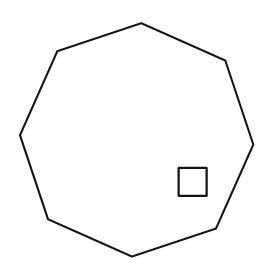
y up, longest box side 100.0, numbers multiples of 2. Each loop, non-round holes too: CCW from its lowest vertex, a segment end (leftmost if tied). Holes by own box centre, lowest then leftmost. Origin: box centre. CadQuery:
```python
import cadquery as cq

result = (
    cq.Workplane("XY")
    .moveTo(-2.0, -50.0)
    .lineTo(34.0, -38.0)
    .lineTo(50.0, -2.0)
    .lineTo(38.0, 34.0)
    .lineTo(2.0, 50.0)
    .lineTo(-34.0, 38.0)
    .lineTo(-50.0, 2.0)
    .lineTo(-38.0, -34.0)
    .close()
    .moveTo(18.0, -24.0)
    .lineTo(30.0, -24.0)
    .lineTo(30.0, -12.0)
    .lineTo(18.0, -12.0)
    .close()
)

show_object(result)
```